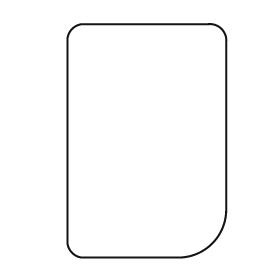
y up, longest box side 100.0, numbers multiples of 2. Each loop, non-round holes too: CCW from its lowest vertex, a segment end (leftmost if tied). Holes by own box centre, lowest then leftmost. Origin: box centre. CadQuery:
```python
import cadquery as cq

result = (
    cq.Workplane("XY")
    .moveTo(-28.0, -50.0)
    .lineTo(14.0, -50.0)
    .threePointArc((28.0, -44.0), (34.0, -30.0))
    .lineTo(34.0, 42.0)
    .threePointArc((32.0, 48.0), (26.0, 50.0))
    .lineTo(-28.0, 50.0)
    .threePointArc((-32.0, 48.0), (-34.0, 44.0))
    .lineTo(-34.0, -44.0)
    .threePointArc((-32.0, -48.0), (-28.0, -50.0))
    .close()
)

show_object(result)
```